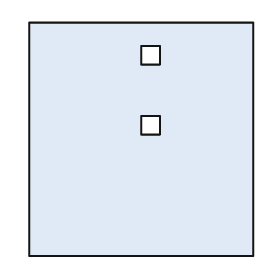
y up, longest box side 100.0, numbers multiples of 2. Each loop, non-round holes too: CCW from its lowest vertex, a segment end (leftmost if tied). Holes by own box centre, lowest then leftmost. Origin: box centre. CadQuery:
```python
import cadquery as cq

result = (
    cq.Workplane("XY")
    .moveTo(-48.0, -50.0)
    .lineTo(48.0, -50.0)
    .lineTo(48.0, 50.0)
    .lineTo(-48.0, 50.0)
    .close()
    .moveTo(0.0, 2.0)
    .lineTo(8.0, 2.0)
    .lineTo(8.0, 10.0)
    .lineTo(0.0, 10.0)
    .close()
    .moveTo(0.0, 32.0)
    .lineTo(8.0, 32.0)
    .lineTo(8.0, 40.0)
    .lineTo(0.0, 40.0)
    .close()
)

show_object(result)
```